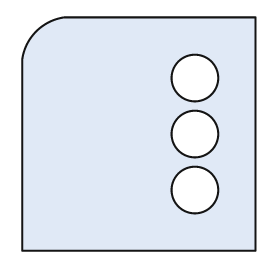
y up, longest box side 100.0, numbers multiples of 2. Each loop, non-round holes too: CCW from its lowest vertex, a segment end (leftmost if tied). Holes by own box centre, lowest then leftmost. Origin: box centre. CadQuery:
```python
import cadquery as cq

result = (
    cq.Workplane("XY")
    .moveTo(-50.0, -50.0)
    .lineTo(50.0, -50.0)
    .lineTo(50.0, 50.0)
    .lineTo(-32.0, 50.0)
    .threePointArc((-44.0, 44.0), (-50.0, 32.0))
    .close()
    .moveTo(24.0, -24.0)
    .circle(10.0)
    .moveTo(24.0, 0.0)
    .circle(10.0)
    .moveTo(24.0, 24.0)
    .circle(10.0)
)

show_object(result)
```